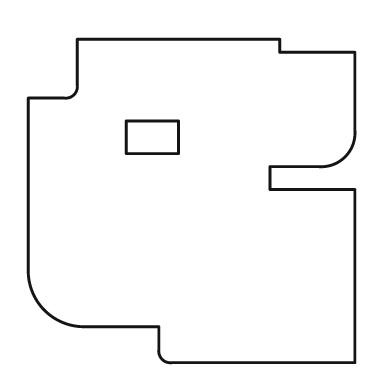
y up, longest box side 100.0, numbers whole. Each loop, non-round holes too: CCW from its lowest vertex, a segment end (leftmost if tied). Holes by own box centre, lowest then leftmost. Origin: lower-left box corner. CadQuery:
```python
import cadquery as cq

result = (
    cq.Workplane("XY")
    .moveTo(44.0, 0.0)
    .lineTo(100.0, 0.0)
    .lineTo(100.0, 53.0)
    .lineTo(74.0, 53.0)
    .lineTo(74.0, 60.0)
    .lineTo(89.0, 60.0)
    .threePointArc((97.0, 63.0), (100.0, 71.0))
    .lineTo(100.0, 95.0)
    .lineTo(77.0, 95.0)
    .lineTo(77.0, 99.0)
    .lineTo(15.0, 99.0)
    .lineTo(15.0, 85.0)
    .threePointArc((14.0, 82.0), (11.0, 81.0))
    .lineTo(0.0, 81.0)
    .lineTo(0.0, 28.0)
    .threePointArc((5.0, 16.0), (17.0, 11.0))
    .lineTo(40.0, 11.0)
    .lineTo(40.0, 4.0)
    .threePointArc((41.0, 1.0), (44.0, 0.0))
    .close()
    .moveTo(30.0, 64.0)
    .lineTo(46.0, 64.0)
    .lineTo(46.0, 74.0)
    .lineTo(30.0, 74.0)
    .close()
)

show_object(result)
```